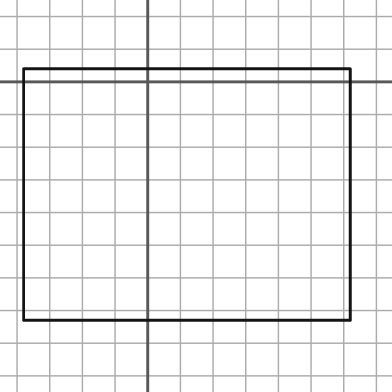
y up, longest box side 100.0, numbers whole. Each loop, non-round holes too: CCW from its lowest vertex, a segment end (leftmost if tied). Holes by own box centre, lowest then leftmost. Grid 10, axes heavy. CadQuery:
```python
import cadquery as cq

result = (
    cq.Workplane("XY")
    .moveTo(-38.0, -73.0)
    .lineTo(62.0, -73.0)
    .lineTo(62.0, 4.0)
    .lineTo(-38.0, 4.0)
    .close()
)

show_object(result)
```